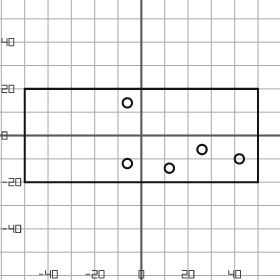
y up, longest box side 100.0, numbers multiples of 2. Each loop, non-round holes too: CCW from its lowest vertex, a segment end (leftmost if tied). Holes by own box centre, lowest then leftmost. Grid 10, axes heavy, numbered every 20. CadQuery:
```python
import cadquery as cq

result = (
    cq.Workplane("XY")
    .moveTo(-50.0, -20.0)
    .lineTo(50.0, -20.0)
    .lineTo(50.0, 20.0)
    .lineTo(-50.0, 20.0)
    .close()
    .moveTo(12.0, -14.0)
    .circle(2.0)
    .moveTo(-6.0, -12.0)
    .circle(2.0)
    .moveTo(42.0, -10.0)
    .circle(2.0)
    .moveTo(26.0, -6.0)
    .circle(2.0)
    .moveTo(-6.0, 14.0)
    .circle(2.0)
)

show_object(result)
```